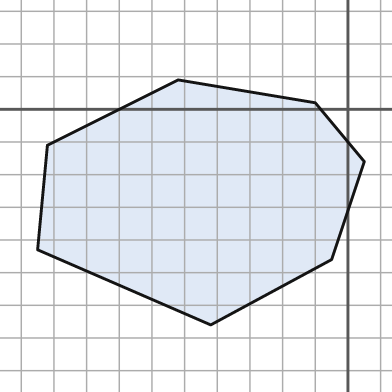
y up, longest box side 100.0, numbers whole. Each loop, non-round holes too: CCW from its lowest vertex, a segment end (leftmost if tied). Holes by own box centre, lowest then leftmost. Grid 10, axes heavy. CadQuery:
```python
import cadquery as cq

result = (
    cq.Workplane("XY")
    .moveTo(-42.0, -66.0)
    .lineTo(-5.0, -46.0)
    .lineTo(5.0, -16.0)
    .lineTo(-10.0, 2.0)
    .lineTo(-52.0, 9.0)
    .lineTo(-92.0, -11.0)
    .lineTo(-95.0, -43.0)
    .close()
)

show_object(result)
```